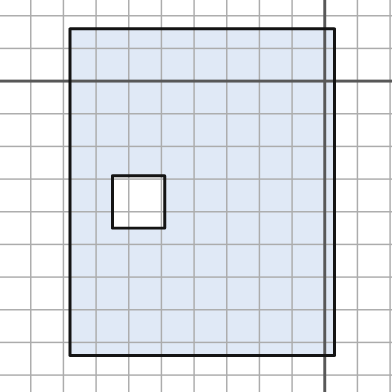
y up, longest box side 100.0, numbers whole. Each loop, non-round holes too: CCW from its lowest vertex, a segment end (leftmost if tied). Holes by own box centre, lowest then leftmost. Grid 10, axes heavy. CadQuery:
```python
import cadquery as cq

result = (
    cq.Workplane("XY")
    .moveTo(-78.0, -84.0)
    .lineTo(3.0, -84.0)
    .lineTo(3.0, 16.0)
    .lineTo(-78.0, 16.0)
    .close()
    .moveTo(-65.0, -45.0)
    .lineTo(-49.0, -45.0)
    .lineTo(-49.0, -29.0)
    .lineTo(-65.0, -29.0)
    .close()
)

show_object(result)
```